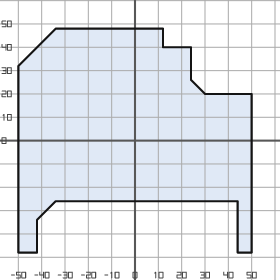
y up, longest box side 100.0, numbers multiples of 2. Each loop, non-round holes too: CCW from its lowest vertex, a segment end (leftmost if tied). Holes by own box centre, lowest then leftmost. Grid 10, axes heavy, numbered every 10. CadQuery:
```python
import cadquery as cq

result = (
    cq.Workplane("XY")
    .moveTo(-50.0, -48.0)
    .lineTo(-42.0, -48.0)
    .lineTo(-42.0, -34.0)
    .lineTo(-34.0, -26.0)
    .lineTo(44.0, -26.0)
    .lineTo(44.0, -48.0)
    .lineTo(50.0, -48.0)
    .lineTo(50.0, 20.0)
    .lineTo(30.0, 20.0)
    .lineTo(24.0, 26.0)
    .lineTo(24.0, 40.0)
    .lineTo(12.0, 40.0)
    .lineTo(12.0, 48.0)
    .lineTo(-34.0, 48.0)
    .lineTo(-50.0, 32.0)
    .close()
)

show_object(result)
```